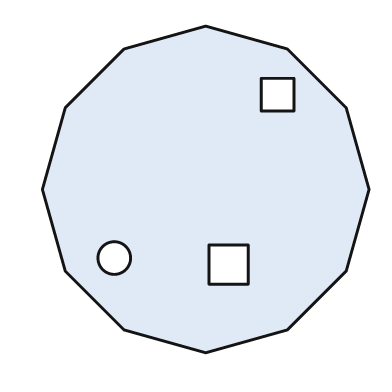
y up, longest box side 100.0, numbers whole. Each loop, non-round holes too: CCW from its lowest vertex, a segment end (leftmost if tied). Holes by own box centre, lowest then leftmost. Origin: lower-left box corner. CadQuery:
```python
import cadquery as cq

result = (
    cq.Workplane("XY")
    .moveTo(50.0, 0.0)
    .lineTo(75.0, 7.0)
    .lineTo(93.0, 25.0)
    .lineTo(100.0, 50.0)
    .lineTo(93.0, 75.0)
    .lineTo(75.0, 93.0)
    .lineTo(50.0, 100.0)
    .lineTo(25.0, 93.0)
    .lineTo(7.0, 75.0)
    .lineTo(0.0, 50.0)
    .lineTo(7.0, 25.0)
    .lineTo(25.0, 7.0)
    .close()
    .moveTo(51.0, 21.0)
    .lineTo(63.0, 21.0)
    .lineTo(63.0, 33.0)
    .lineTo(51.0, 33.0)
    .close()
    .moveTo(22.0, 29.0)
    .circle(5.0)
    .moveTo(67.0, 74.0)
    .lineTo(77.0, 74.0)
    .lineTo(77.0, 84.0)
    .lineTo(67.0, 84.0)
    .close()
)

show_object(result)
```